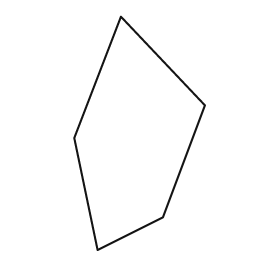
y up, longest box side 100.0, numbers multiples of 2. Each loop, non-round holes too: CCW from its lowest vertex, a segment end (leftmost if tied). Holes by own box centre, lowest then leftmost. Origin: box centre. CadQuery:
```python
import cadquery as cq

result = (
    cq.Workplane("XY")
    .moveTo(-18.0, -50.0)
    .lineTo(10.0, -36.0)
    .lineTo(28.0, 12.0)
    .lineTo(-8.0, 50.0)
    .lineTo(-28.0, -2.0)
    .close()
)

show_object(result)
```